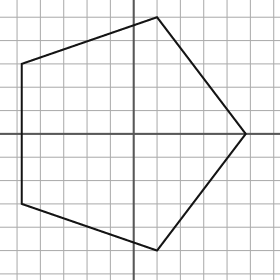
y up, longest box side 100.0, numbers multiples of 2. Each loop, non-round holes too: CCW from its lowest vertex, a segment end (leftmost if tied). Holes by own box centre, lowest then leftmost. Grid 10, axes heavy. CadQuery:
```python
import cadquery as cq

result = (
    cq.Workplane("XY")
    .moveTo(10.0, -50.0)
    .lineTo(48.0, 0.0)
    .lineTo(10.0, 50.0)
    .lineTo(-48.0, 30.0)
    .lineTo(-48.0, -30.0)
    .close()
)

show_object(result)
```